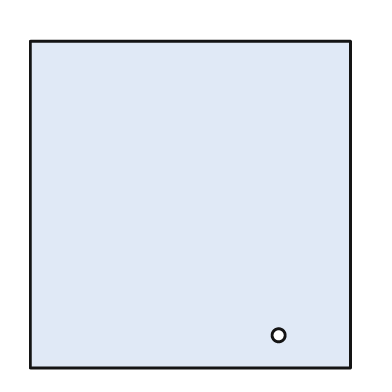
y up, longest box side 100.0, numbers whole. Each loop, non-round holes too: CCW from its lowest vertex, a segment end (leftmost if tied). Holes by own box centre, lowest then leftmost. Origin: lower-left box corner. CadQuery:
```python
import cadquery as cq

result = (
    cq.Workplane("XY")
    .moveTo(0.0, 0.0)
    .lineTo(98.0, 0.0)
    .lineTo(98.0, 100.0)
    .lineTo(0.0, 100.0)
    .close()
    .moveTo(76.0, 10.0)
    .circle(2.0)
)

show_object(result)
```